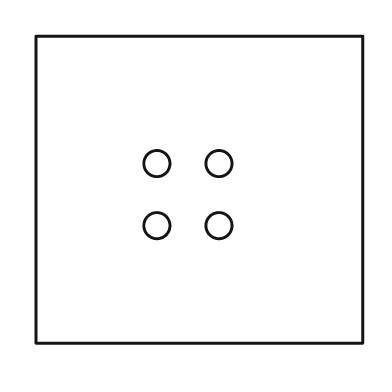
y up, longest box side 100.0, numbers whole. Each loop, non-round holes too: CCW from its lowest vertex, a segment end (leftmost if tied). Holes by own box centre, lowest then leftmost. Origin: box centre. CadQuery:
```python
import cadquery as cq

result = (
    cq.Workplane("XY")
    .moveTo(-50.0, -47.0)
    .lineTo(50.0, -47.0)
    .lineTo(50.0, 47.0)
    .lineTo(-50.0, 47.0)
    .close()
    .moveTo(-13.0, -11.0)
    .circle(4.0)
    .moveTo(6.0, -11.0)
    .circle(4.0)
    .moveTo(-13.0, 8.0)
    .circle(4.0)
    .moveTo(6.0, 8.0)
    .circle(4.0)
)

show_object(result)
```